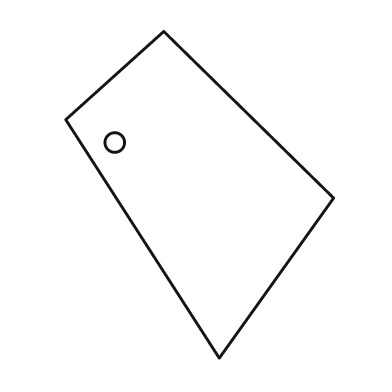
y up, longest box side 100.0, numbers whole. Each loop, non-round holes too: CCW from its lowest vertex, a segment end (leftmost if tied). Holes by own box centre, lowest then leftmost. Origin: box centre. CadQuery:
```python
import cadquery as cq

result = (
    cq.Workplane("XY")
    .moveTo(6.0, -50.0)
    .lineTo(41.0, -1.0)
    .lineTo(-11.0, 50.0)
    .lineTo(-41.0, 23.0)
    .close()
    .moveTo(-26.0, 16.0)
    .circle(3.0)
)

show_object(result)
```